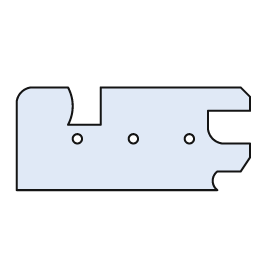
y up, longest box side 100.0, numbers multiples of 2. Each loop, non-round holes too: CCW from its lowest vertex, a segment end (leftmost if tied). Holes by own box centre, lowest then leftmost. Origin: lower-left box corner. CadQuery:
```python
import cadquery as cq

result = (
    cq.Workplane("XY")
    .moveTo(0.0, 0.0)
    .lineTo(86.0, 0.0)
    .threePointArc((84.0, 4.0), (86.0, 8.0))
    .lineTo(96.0, 8.0)
    .lineTo(100.0, 14.0)
    .lineTo(100.0, 20.0)
    .lineTo(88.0, 20.0)
    .threePointArc((84.0, 22.0), (82.0, 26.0))
    .lineTo(82.0, 34.0)
    .lineTo(100.0, 34.0)
    .lineTo(100.0, 40.0)
    .lineTo(96.0, 44.0)
    .lineTo(36.0, 44.0)
    .lineTo(36.0, 28.0)
    .lineTo(22.0, 28.0)
    .threePointArc((24.0, 36.0), (22.0, 44.0))
    .lineTo(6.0, 44.0)
    .threePointArc((2.0, 42.0), (0.0, 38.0))
    .close()
    .moveTo(26.0, 22.0)
    .circle(2.0)
    .moveTo(50.0, 22.0)
    .circle(2.0)
    .moveTo(74.0, 22.0)
    .circle(2.0)
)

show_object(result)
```